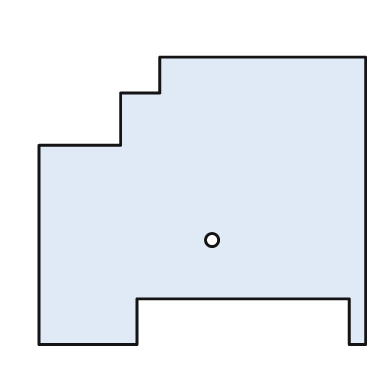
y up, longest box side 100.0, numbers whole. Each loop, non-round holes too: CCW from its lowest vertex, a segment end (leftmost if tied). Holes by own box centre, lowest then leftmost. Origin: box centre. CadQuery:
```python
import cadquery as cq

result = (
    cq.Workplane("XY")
    .moveTo(-50.0, -44.0)
    .lineTo(-20.0, -44.0)
    .lineTo(-20.0, -30.0)
    .lineTo(45.0, -30.0)
    .lineTo(45.0, -44.0)
    .lineTo(50.0, -44.0)
    .lineTo(50.0, 44.0)
    .lineTo(-13.0, 44.0)
    .lineTo(-13.0, 33.0)
    .lineTo(-25.0, 33.0)
    .lineTo(-25.0, 17.0)
    .lineTo(-50.0, 17.0)
    .close()
    .moveTo(3.0, -12.0)
    .circle(2.0)
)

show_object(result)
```